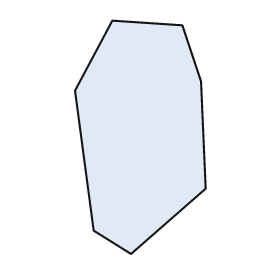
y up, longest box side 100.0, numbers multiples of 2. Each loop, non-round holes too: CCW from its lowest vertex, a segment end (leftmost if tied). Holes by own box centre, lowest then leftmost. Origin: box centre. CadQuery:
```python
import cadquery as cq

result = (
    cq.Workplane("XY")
    .moveTo(-4.0, -50.0)
    .lineTo(28.0, -22.0)
    .lineTo(26.0, 24.0)
    .lineTo(18.0, 48.0)
    .lineTo(-12.0, 50.0)
    .lineTo(-28.0, 20.0)
    .lineTo(-20.0, -40.0)
    .close()
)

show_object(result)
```